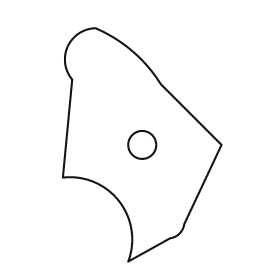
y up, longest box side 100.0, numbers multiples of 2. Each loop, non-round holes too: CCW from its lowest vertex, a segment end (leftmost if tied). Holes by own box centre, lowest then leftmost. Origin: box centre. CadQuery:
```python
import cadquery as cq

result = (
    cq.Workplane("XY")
    .moveTo(-6.0, -50.0)
    .lineTo(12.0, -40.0)
    .threePointArc((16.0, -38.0), (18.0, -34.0))
    .lineTo(34.0, 0.0)
    .lineTo(8.0, 26.0)
    .threePointArc((-4.0, 40.0), (-20.0, 50.0))
    .threePointArc((-32.0, 42.0), (-30.0, 28.0))
    .lineTo(-34.0, -14.0)
    .threePointArc((-10.0, -24.0), (-6.0, -50.0))
    .close()
    .moveTo(0.0, 0.0)
    .circle(6.0)
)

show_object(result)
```